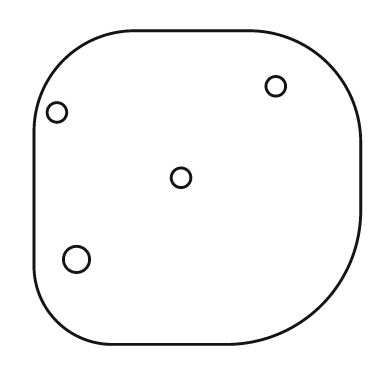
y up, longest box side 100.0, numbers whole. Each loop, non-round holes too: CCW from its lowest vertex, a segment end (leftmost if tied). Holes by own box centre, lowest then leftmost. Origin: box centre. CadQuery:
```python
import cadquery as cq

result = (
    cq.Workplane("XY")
    .moveTo(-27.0, -48.0)
    .lineTo(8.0, -48.0)
    .threePointArc((38.0, -36.0), (50.0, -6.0))
    .lineTo(50.0, 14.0)
    .threePointArc((40.0, 38.0), (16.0, 48.0))
    .lineTo(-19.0, 48.0)
    .threePointArc((-41.0, 39.0), (-50.0, 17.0))
    .lineTo(-50.0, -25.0)
    .threePointArc((-43.0, -41.0), (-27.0, -48.0))
    .close()
    .moveTo(-37.0, -22.0)
    .circle(4.0)
    .moveTo(-5.0, 3.0)
    .circle(3.0)
    .moveTo(-43.0, 23.0)
    .circle(3.0)
    .moveTo(24.0, 31.0)
    .circle(3.0)
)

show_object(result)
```